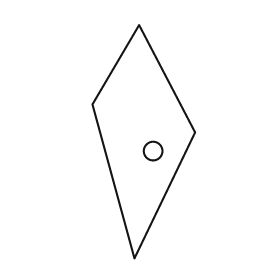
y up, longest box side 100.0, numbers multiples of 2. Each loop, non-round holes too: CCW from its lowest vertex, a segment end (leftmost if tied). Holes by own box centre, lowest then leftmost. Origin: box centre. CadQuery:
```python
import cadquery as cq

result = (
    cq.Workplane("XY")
    .moveTo(-4.0, -50.0)
    .lineTo(22.0, 4.0)
    .lineTo(-2.0, 50.0)
    .lineTo(-22.0, 16.0)
    .close()
    .moveTo(4.0, -4.0)
    .circle(4.0)
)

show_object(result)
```